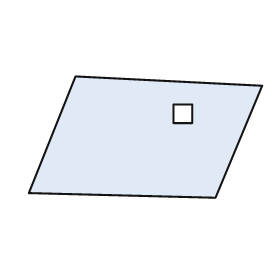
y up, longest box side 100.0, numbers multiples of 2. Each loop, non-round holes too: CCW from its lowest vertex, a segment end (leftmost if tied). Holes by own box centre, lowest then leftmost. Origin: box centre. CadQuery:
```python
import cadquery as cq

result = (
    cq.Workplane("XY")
    .moveTo(30.0, -26.0)
    .lineTo(50.0, 22.0)
    .lineTo(-30.0, 26.0)
    .lineTo(-50.0, -24.0)
    .close()
    .moveTo(12.0, 6.0)
    .lineTo(20.0, 6.0)
    .lineTo(20.0, 14.0)
    .lineTo(12.0, 14.0)
    .close()
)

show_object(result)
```